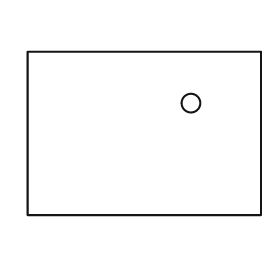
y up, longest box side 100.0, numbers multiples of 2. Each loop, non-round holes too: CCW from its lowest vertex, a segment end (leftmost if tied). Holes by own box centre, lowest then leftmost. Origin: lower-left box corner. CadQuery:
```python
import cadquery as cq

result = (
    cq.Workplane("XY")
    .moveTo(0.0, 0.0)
    .lineTo(100.0, 0.0)
    .lineTo(100.0, 70.0)
    .lineTo(0.0, 70.0)
    .close()
    .moveTo(70.0, 48.0)
    .circle(4.0)
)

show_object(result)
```